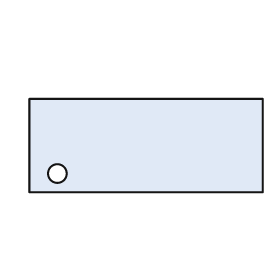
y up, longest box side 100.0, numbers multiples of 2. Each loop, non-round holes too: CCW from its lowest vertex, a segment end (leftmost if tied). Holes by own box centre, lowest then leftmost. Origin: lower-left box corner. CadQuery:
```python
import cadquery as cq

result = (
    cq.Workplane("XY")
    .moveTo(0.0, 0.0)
    .lineTo(100.0, 0.0)
    .lineTo(100.0, 40.0)
    .lineTo(0.0, 40.0)
    .close()
    .moveTo(12.0, 8.0)
    .circle(4.0)
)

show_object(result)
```